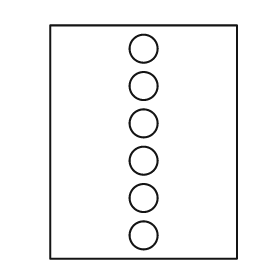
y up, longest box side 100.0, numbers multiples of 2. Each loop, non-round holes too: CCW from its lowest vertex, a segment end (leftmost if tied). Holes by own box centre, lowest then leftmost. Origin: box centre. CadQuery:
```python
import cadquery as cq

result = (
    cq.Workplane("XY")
    .moveTo(-40.0, -50.0)
    .lineTo(40.0, -50.0)
    .lineTo(40.0, 50.0)
    .lineTo(-40.0, 50.0)
    .close()
    .moveTo(0.0, -40.0)
    .circle(6.0)
    .moveTo(0.0, -24.0)
    .circle(6.0)
    .moveTo(0.0, -8.0)
    .circle(6.0)
    .moveTo(0.0, 8.0)
    .circle(6.0)
    .moveTo(0.0, 24.0)
    .circle(6.0)
    .moveTo(0.0, 40.0)
    .circle(6.0)
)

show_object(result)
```